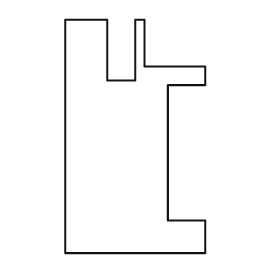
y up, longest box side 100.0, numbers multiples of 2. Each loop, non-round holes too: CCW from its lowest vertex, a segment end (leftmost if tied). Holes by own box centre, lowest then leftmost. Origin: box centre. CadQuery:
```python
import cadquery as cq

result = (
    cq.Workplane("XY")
    .moveTo(-30.0, -50.0)
    .lineTo(30.0, -50.0)
    .lineTo(30.0, -36.0)
    .lineTo(14.0, -36.0)
    .lineTo(14.0, 22.0)
    .lineTo(30.0, 22.0)
    .lineTo(30.0, 30.0)
    .lineTo(4.0, 30.0)
    .lineTo(4.0, 50.0)
    .lineTo(0.0, 50.0)
    .lineTo(0.0, 24.0)
    .lineTo(-12.0, 24.0)
    .lineTo(-12.0, 50.0)
    .lineTo(-30.0, 50.0)
    .close()
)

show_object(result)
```